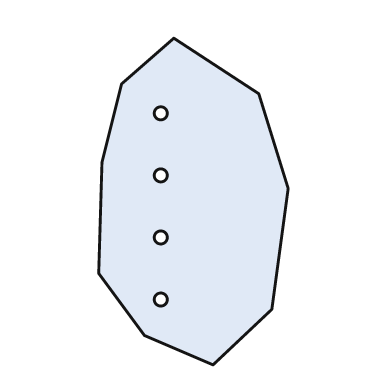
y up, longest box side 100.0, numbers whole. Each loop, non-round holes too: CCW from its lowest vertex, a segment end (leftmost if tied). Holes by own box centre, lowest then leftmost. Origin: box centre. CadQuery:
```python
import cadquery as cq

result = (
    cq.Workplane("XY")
    .moveTo(6.0, -50.0)
    .lineTo(24.0, -33.0)
    .lineTo(29.0, 4.0)
    .lineTo(20.0, 33.0)
    .lineTo(-6.0, 50.0)
    .lineTo(-22.0, 36.0)
    .lineTo(-28.0, 12.0)
    .lineTo(-29.0, -22.0)
    .lineTo(-15.0, -41.0)
    .close()
    .moveTo(-10.0, -30.0)
    .circle(2.0)
    .moveTo(-10.0, -11.0)
    .circle(2.0)
    .moveTo(-10.0, 8.0)
    .circle(2.0)
    .moveTo(-10.0, 27.0)
    .circle(2.0)
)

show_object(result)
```